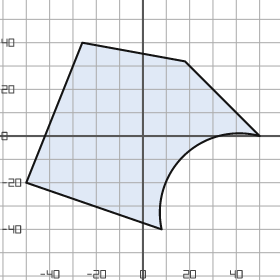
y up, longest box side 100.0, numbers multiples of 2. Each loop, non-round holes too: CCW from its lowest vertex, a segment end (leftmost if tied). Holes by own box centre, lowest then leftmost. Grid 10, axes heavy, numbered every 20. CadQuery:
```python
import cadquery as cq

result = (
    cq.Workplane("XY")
    .moveTo(8.0, -40.0)
    .threePointArc((18.0, -8.0), (50.0, 0.0))
    .lineTo(18.0, 32.0)
    .lineTo(-26.0, 40.0)
    .lineTo(-50.0, -20.0)
    .close()
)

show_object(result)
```